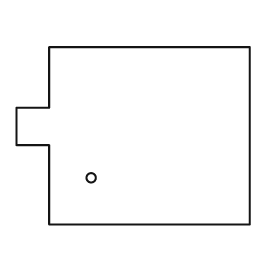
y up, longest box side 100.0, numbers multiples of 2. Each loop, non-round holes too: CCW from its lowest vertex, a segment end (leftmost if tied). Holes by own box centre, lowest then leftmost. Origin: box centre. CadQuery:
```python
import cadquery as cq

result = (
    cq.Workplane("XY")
    .moveTo(-36.0, -38.0)
    .lineTo(50.0, -38.0)
    .lineTo(50.0, 38.0)
    .lineTo(-36.0, 38.0)
    .lineTo(-36.0, 12.0)
    .lineTo(-50.0, 12.0)
    .lineTo(-50.0, -4.0)
    .lineTo(-36.0, -4.0)
    .close()
    .moveTo(-18.0, -18.0)
    .circle(2.0)
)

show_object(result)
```